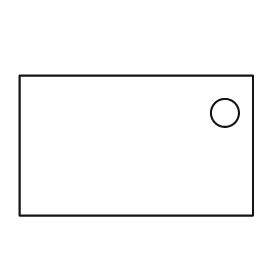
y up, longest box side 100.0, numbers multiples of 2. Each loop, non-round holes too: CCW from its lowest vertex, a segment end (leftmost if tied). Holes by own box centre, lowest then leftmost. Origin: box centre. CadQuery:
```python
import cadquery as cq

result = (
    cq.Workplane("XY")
    .moveTo(-50.0, -30.0)
    .lineTo(50.0, -30.0)
    .lineTo(50.0, 30.0)
    .lineTo(-50.0, 30.0)
    .close()
    .moveTo(38.0, 14.0)
    .circle(6.0)
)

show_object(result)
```